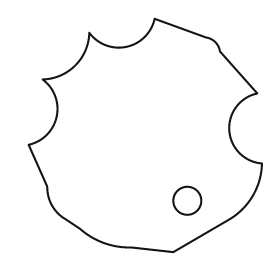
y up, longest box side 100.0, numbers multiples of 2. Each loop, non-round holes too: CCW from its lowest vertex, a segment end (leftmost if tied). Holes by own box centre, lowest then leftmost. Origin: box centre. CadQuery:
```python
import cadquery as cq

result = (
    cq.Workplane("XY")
    .moveTo(12.0, -50.0)
    .lineTo(36.0, -36.0)
    .threePointArc((46.0, -26.0), (50.0, -12.0))
    .threePointArc((36.0, 2.0), (48.0, 18.0))
    .lineTo(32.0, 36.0)
    .threePointArc((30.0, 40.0), (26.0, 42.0))
    .lineTo(4.0, 50.0)
    .threePointArc((-8.0, 38.0), (-24.0, 44.0))
    .threePointArc((-30.0, 30.0), (-44.0, 24.0))
    .threePointArc((-38.0, 8.0), (-50.0, -4.0))
    .lineTo(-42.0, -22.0)
    .threePointArc((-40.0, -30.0), (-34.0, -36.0))
    .lineTo(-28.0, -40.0)
    .threePointArc((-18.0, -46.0), (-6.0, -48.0))
    .close()
    .moveTo(18.0, -28.0)
    .circle(6.0)
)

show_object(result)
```